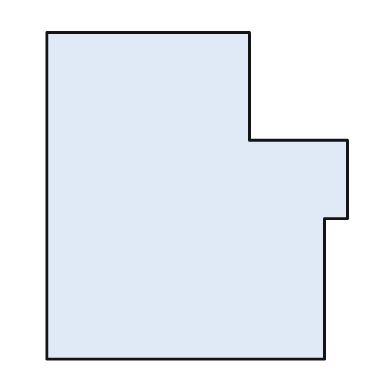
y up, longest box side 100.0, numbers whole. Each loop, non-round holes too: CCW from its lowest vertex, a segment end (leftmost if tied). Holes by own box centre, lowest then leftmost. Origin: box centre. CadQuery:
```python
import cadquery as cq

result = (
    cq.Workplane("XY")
    .moveTo(-46.0, -50.0)
    .lineTo(39.0, -50.0)
    .lineTo(39.0, -7.0)
    .lineTo(46.0, -7.0)
    .lineTo(46.0, 17.0)
    .lineTo(16.0, 17.0)
    .lineTo(16.0, 50.0)
    .lineTo(-46.0, 50.0)
    .close()
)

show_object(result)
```